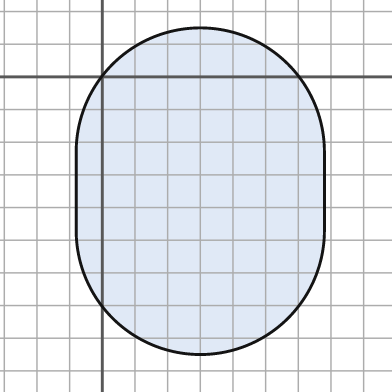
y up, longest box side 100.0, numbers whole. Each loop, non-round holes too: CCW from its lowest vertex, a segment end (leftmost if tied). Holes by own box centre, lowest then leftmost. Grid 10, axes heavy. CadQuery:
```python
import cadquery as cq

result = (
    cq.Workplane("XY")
    .moveTo(-8.0, -47.0)
    .threePointArc((30.0, -85.0), (68.0, -47.0))
    .lineTo(68.0, -23.0)
    .threePointArc((30.0, 15.0), (-8.0, -23.0))
    .close()
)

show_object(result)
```